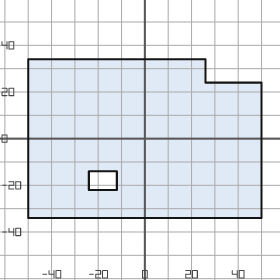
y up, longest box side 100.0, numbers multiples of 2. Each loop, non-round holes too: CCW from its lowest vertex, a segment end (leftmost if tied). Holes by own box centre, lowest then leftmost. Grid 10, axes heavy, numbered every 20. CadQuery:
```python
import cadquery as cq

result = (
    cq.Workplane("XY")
    .moveTo(-50.0, -34.0)
    .lineTo(50.0, -34.0)
    .lineTo(50.0, 24.0)
    .lineTo(26.0, 24.0)
    .lineTo(26.0, 34.0)
    .lineTo(-50.0, 34.0)
    .close()
    .moveTo(-24.0, -22.0)
    .lineTo(-12.0, -22.0)
    .lineTo(-12.0, -14.0)
    .lineTo(-24.0, -14.0)
    .close()
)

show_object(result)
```